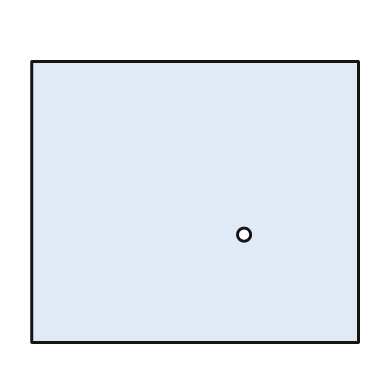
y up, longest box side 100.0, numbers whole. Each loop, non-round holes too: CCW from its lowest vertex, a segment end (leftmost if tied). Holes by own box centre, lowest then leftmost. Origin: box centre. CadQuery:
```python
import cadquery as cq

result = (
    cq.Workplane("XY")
    .moveTo(-50.0, -43.0)
    .lineTo(50.0, -43.0)
    .lineTo(50.0, 43.0)
    .lineTo(-50.0, 43.0)
    .close()
    .moveTo(15.0, -10.0)
    .circle(2.0)
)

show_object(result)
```